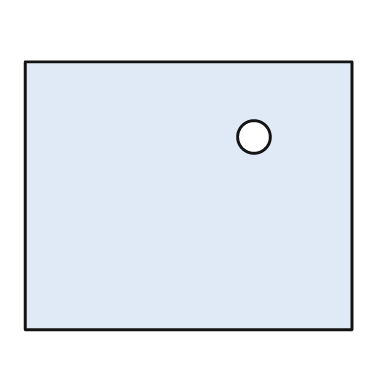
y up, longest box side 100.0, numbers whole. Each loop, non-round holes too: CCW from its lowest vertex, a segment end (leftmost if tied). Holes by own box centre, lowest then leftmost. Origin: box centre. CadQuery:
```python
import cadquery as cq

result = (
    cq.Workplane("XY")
    .moveTo(-50.0, -41.0)
    .lineTo(50.0, -41.0)
    .lineTo(50.0, 41.0)
    .lineTo(-50.0, 41.0)
    .close()
    .moveTo(20.0, 18.0)
    .circle(5.0)
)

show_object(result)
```